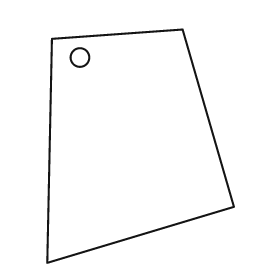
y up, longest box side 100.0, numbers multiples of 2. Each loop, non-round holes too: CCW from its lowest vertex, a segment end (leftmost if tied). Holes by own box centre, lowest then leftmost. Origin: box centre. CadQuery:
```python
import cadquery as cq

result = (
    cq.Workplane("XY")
    .moveTo(-40.0, -50.0)
    .lineTo(40.0, -26.0)
    .lineTo(18.0, 50.0)
    .lineTo(-38.0, 46.0)
    .close()
    .moveTo(-26.0, 38.0)
    .circle(4.0)
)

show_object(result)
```